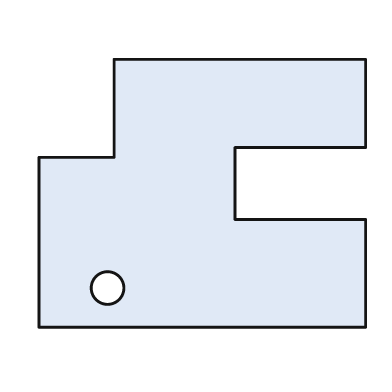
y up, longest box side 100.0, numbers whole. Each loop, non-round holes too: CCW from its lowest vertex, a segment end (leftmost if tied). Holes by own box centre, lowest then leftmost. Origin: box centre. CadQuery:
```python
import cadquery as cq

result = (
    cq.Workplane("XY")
    .moveTo(-50.0, -41.0)
    .lineTo(50.0, -41.0)
    .lineTo(50.0, -8.0)
    .lineTo(10.0, -8.0)
    .lineTo(10.0, 14.0)
    .lineTo(50.0, 14.0)
    .lineTo(50.0, 41.0)
    .lineTo(-27.0, 41.0)
    .lineTo(-27.0, 11.0)
    .lineTo(-50.0, 11.0)
    .close()
    .moveTo(-29.0, -29.0)
    .circle(5.0)
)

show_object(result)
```